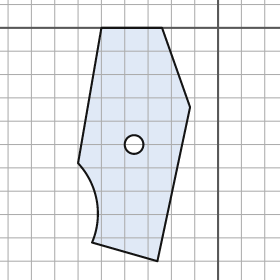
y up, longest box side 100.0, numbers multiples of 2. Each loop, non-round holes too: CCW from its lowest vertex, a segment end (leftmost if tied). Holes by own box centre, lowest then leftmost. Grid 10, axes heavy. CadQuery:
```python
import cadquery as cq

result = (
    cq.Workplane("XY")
    .moveTo(-26.0, -100.0)
    .lineTo(-12.0, -34.0)
    .lineTo(-24.0, 0.0)
    .lineTo(-50.0, 0.0)
    .lineTo(-60.0, -58.0)
    .threePointArc((-52.0, -74.0), (-54.0, -92.0))
    .close()
    .moveTo(-36.0, -50.0)
    .circle(4.0)
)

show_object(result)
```